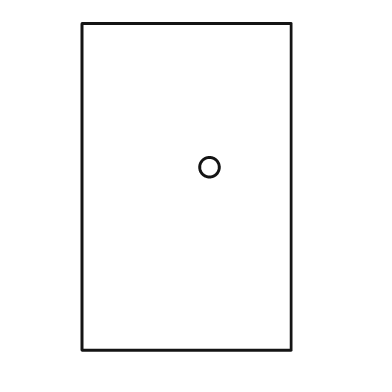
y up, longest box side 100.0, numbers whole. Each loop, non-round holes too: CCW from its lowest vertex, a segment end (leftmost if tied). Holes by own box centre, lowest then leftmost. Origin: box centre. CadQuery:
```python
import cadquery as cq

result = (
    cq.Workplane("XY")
    .moveTo(-32.0, -50.0)
    .lineTo(32.0, -50.0)
    .lineTo(32.0, 50.0)
    .lineTo(-32.0, 50.0)
    .close()
    .moveTo(7.0, 6.0)
    .circle(3.0)
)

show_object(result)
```